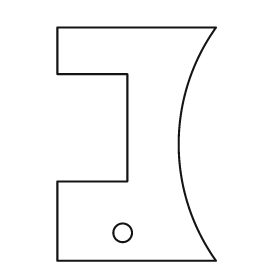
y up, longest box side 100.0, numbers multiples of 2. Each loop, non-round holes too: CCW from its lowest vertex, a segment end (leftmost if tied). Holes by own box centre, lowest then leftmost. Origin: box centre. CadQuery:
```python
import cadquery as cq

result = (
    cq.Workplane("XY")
    .moveTo(-34.0, -50.0)
    .lineTo(34.0, -50.0)
    .threePointArc((18.0, 0.0), (34.0, 50.0))
    .lineTo(-34.0, 50.0)
    .lineTo(-34.0, 30.0)
    .lineTo(-4.0, 30.0)
    .lineTo(-4.0, -16.0)
    .lineTo(-34.0, -16.0)
    .close()
    .moveTo(-6.0, -38.0)
    .circle(4.0)
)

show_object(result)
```